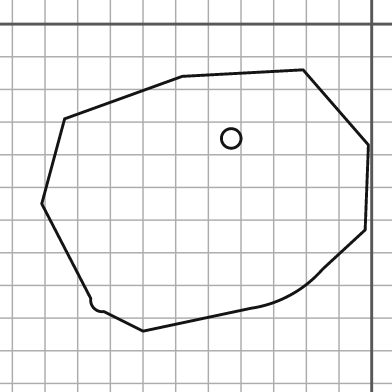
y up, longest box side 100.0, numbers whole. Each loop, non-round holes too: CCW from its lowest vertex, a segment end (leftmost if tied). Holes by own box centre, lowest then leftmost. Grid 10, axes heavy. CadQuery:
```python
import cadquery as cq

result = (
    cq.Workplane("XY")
    .moveTo(-70.0, -94.0)
    .lineTo(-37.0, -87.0)
    .threePointArc((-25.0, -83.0), (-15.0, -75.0))
    .lineTo(-2.0, -63.0)
    .lineTo(-1.0, -37.0)
    .lineTo(-21.0, -14.0)
    .lineTo(-58.0, -16.0)
    .lineTo(-94.0, -29.0)
    .lineTo(-101.0, -55.0)
    .lineTo(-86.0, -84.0)
    .threePointArc((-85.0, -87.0), (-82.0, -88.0))
    .close()
    .moveTo(-43.0, -35.0)
    .circle(3.0)
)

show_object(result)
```